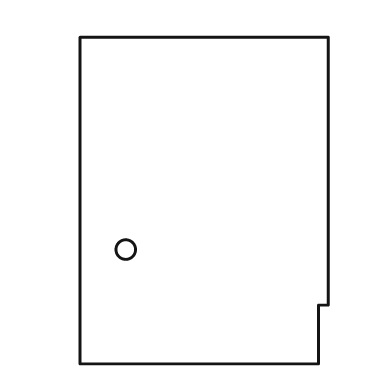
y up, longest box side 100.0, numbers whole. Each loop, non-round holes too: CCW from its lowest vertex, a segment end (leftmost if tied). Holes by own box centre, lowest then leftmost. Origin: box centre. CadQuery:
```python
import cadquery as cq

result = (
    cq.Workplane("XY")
    .moveTo(-38.0, -50.0)
    .lineTo(35.0, -50.0)
    .lineTo(35.0, -32.0)
    .lineTo(38.0, -32.0)
    .lineTo(38.0, 50.0)
    .lineTo(-38.0, 50.0)
    .close()
    .moveTo(-24.0, -15.0)
    .circle(3.0)
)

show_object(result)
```